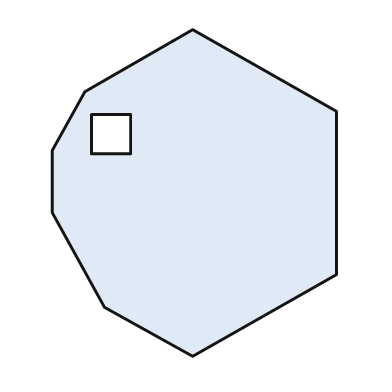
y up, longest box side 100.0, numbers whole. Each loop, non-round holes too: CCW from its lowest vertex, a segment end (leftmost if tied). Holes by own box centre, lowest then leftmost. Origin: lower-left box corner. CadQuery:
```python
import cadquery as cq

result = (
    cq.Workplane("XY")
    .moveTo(43.0, 0.0)
    .lineTo(87.0, 25.0)
    .lineTo(87.0, 75.0)
    .lineTo(43.0, 100.0)
    .lineTo(10.0, 81.0)
    .lineTo(0.0, 63.0)
    .lineTo(0.0, 44.0)
    .lineTo(16.0, 15.0)
    .close()
    .moveTo(12.0, 62.0)
    .lineTo(24.0, 62.0)
    .lineTo(24.0, 74.0)
    .lineTo(12.0, 74.0)
    .close()
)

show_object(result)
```